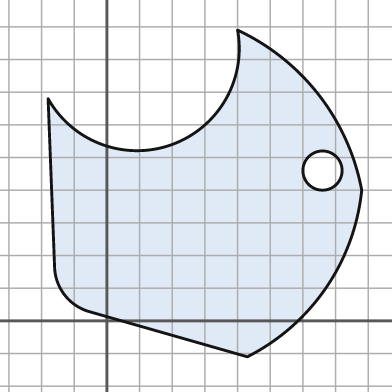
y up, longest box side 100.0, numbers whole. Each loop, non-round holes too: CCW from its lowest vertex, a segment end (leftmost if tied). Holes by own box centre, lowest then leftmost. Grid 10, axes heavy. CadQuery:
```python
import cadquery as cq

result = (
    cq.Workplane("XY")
    .moveTo(43.0, -11.0)
    .threePointArc((67.0, 10.0), (78.0, 40.0))
    .threePointArc((65.0, 69.0), (40.0, 89.0))
    .threePointArc((20.0, 54.0), (-18.0, 68.0))
    .lineTo(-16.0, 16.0)
    .threePointArc((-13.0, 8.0), (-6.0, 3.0))
    .close()
    .moveTo(66.0, 46.0)
    .circle(6.0)
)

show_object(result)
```